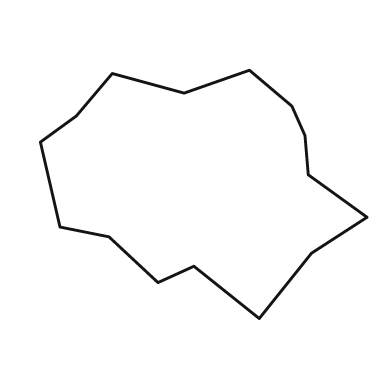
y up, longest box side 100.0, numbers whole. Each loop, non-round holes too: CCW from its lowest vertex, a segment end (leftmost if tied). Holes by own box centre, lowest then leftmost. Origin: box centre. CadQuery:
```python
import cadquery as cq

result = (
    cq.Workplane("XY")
    .moveTo(17.0, -38.0)
    .lineTo(33.0, -18.0)
    .lineTo(50.0, -7.0)
    .lineTo(32.0, 6.0)
    .lineTo(31.0, 18.0)
    .lineTo(27.0, 27.0)
    .lineTo(14.0, 38.0)
    .lineTo(-6.0, 31.0)
    .lineTo(-28.0, 37.0)
    .lineTo(-39.0, 24.0)
    .lineTo(-50.0, 16.0)
    .lineTo(-44.0, -10.0)
    .lineTo(-29.0, -13.0)
    .lineTo(-14.0, -27.0)
    .lineTo(-3.0, -22.0)
    .close()
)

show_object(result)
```